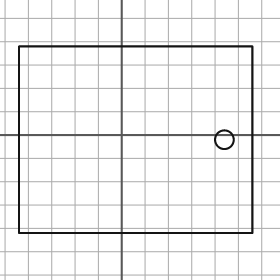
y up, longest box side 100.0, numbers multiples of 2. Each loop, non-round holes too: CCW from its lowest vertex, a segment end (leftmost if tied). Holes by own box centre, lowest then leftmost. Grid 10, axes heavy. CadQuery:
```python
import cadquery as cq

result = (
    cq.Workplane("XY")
    .moveTo(-44.0, -42.0)
    .lineTo(56.0, -42.0)
    .lineTo(56.0, 38.0)
    .lineTo(-44.0, 38.0)
    .close()
    .moveTo(44.0, -2.0)
    .circle(4.0)
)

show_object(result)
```